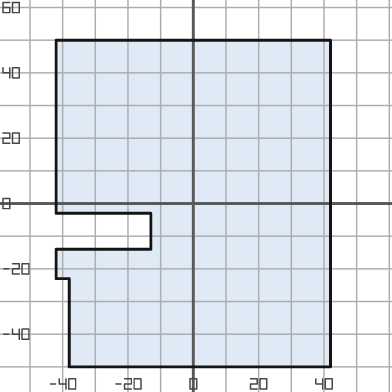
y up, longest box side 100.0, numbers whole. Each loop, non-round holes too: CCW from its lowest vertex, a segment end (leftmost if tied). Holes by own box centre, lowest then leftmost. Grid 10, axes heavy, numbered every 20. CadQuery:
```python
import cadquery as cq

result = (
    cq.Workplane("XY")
    .moveTo(-38.0, -50.0)
    .lineTo(42.0, -50.0)
    .lineTo(42.0, 50.0)
    .lineTo(-42.0, 50.0)
    .lineTo(-42.0, -3.0)
    .lineTo(-13.0, -3.0)
    .lineTo(-13.0, -14.0)
    .lineTo(-42.0, -14.0)
    .lineTo(-42.0, -23.0)
    .lineTo(-38.0, -23.0)
    .close()
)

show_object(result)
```